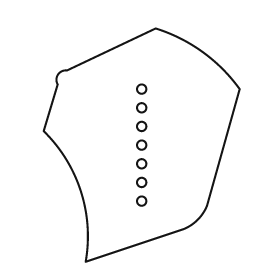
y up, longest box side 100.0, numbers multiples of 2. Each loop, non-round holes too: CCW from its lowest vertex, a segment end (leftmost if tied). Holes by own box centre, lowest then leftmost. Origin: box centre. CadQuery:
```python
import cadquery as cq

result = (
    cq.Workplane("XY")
    .moveTo(-24.0, -50.0)
    .lineTo(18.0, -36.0)
    .threePointArc((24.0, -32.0), (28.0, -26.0))
    .lineTo(42.0, 24.0)
    .threePointArc((26.0, 40.0), (6.0, 50.0))
    .lineTo(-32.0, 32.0)
    .threePointArc((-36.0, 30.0), (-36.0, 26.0))
    .lineTo(-42.0, 6.0)
    .threePointArc((-26.0, -20.0), (-24.0, -50.0))
    .close()
    .moveTo(0.0, -24.0)
    .circle(2.0)
    .moveTo(0.0, -16.0)
    .circle(2.0)
    .moveTo(0.0, -8.0)
    .circle(2.0)
    .moveTo(0.0, 0.0)
    .circle(2.0)
    .moveTo(0.0, 8.0)
    .circle(2.0)
    .moveTo(0.0, 16.0)
    .circle(2.0)
    .moveTo(0.0, 24.0)
    .circle(2.0)
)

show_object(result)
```